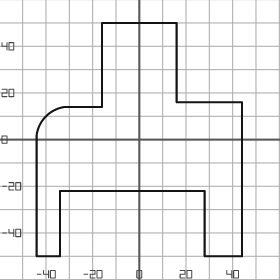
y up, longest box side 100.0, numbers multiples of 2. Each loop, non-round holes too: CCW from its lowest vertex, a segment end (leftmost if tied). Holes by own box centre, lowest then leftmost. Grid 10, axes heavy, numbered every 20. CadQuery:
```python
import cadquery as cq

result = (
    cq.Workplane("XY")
    .moveTo(-44.0, -50.0)
    .lineTo(-34.0, -50.0)
    .lineTo(-34.0, -22.0)
    .lineTo(28.0, -22.0)
    .lineTo(28.0, -50.0)
    .lineTo(44.0, -50.0)
    .lineTo(44.0, 16.0)
    .lineTo(16.0, 16.0)
    .lineTo(16.0, 50.0)
    .lineTo(-16.0, 50.0)
    .lineTo(-16.0, 14.0)
    .lineTo(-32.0, 14.0)
    .threePointArc((-40.0, 10.0), (-44.0, 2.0))
    .close()
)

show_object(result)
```